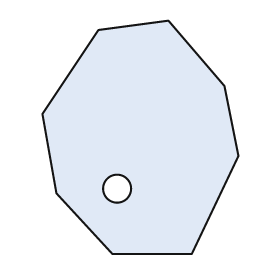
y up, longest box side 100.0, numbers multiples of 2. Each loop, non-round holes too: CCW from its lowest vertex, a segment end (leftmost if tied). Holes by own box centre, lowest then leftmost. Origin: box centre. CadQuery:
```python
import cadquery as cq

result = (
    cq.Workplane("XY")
    .moveTo(-12.0, -50.0)
    .lineTo(22.0, -50.0)
    .lineTo(42.0, -8.0)
    .lineTo(36.0, 22.0)
    .lineTo(12.0, 50.0)
    .lineTo(-18.0, 46.0)
    .lineTo(-42.0, 10.0)
    .lineTo(-36.0, -24.0)
    .close()
    .moveTo(-10.0, -22.0)
    .circle(6.0)
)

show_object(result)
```